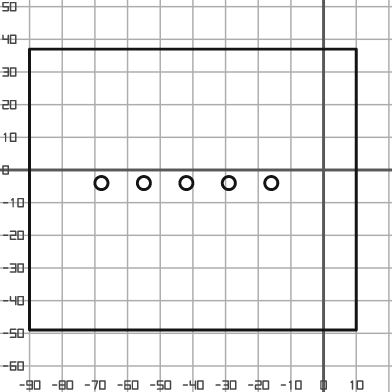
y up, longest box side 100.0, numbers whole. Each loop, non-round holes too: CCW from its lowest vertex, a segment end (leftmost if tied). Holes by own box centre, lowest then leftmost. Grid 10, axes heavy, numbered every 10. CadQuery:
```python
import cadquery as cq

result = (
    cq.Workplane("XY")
    .moveTo(-90.0, -49.0)
    .lineTo(10.0, -49.0)
    .lineTo(10.0, 37.0)
    .lineTo(-90.0, 37.0)
    .close()
    .moveTo(-68.0, -4.0)
    .circle(2.0)
    .moveTo(-55.0, -4.0)
    .circle(2.0)
    .moveTo(-42.0, -4.0)
    .circle(2.0)
    .moveTo(-29.0, -4.0)
    .circle(2.0)
    .moveTo(-16.0, -4.0)
    .circle(2.0)
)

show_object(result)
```